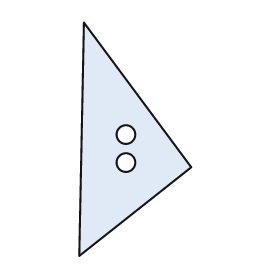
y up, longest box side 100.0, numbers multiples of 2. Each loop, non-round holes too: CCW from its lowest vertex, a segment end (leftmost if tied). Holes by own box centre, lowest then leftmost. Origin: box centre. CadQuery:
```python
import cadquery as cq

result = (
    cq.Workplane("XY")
    .moveTo(-24.0, -50.0)
    .lineTo(24.0, -12.0)
    .lineTo(-22.0, 50.0)
    .close()
    .moveTo(-4.0, -10.0)
    .circle(4.0)
    .moveTo(-4.0, 2.0)
    .circle(4.0)
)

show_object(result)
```